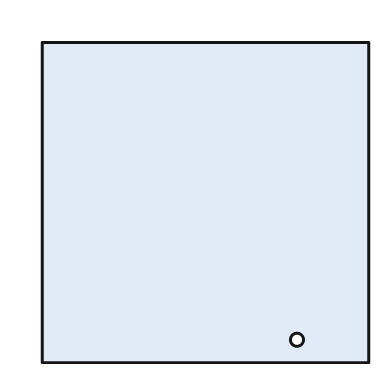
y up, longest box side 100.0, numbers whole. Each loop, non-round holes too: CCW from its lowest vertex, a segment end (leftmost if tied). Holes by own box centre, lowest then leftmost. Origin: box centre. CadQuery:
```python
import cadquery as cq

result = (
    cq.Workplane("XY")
    .moveTo(-50.0, -49.0)
    .lineTo(50.0, -49.0)
    .lineTo(50.0, 49.0)
    .lineTo(-50.0, 49.0)
    .close()
    .moveTo(28.0, -42.0)
    .circle(2.0)
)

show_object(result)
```